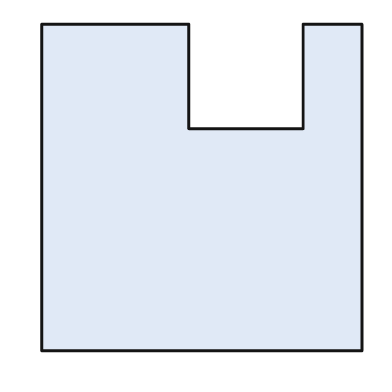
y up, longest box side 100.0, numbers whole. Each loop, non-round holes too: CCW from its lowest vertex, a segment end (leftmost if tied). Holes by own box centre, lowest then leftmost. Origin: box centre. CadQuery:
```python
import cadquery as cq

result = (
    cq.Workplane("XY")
    .moveTo(-49.0, -50.0)
    .lineTo(49.0, -50.0)
    .lineTo(49.0, 50.0)
    .lineTo(31.0, 50.0)
    .lineTo(31.0, 18.0)
    .lineTo(-4.0, 18.0)
    .lineTo(-4.0, 50.0)
    .lineTo(-49.0, 50.0)
    .close()
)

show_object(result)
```